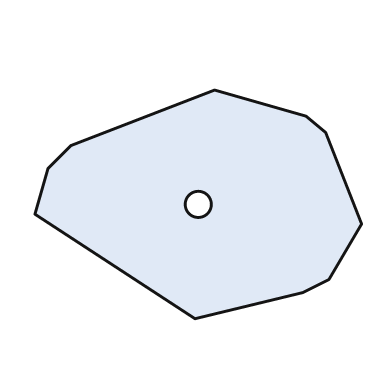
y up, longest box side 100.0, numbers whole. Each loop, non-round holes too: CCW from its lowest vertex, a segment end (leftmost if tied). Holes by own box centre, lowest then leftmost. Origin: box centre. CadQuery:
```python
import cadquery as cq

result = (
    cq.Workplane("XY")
    .moveTo(-1.0, -35.0)
    .lineTo(32.0, -27.0)
    .lineTo(40.0, -23.0)
    .lineTo(50.0, -6.0)
    .lineTo(39.0, 22.0)
    .lineTo(33.0, 27.0)
    .lineTo(5.0, 35.0)
    .lineTo(-39.0, 18.0)
    .lineTo(-46.0, 11.0)
    .lineTo(-50.0, -3.0)
    .close()
    .moveTo(0.0, 0.0)
    .circle(4.0)
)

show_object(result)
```